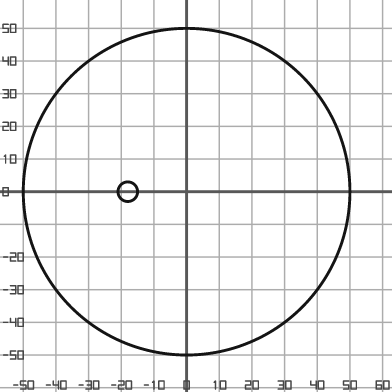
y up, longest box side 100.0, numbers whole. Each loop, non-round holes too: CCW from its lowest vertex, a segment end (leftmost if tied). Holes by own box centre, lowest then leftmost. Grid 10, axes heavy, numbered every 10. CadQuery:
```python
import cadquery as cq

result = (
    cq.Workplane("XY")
    .moveTo(0.0, 0.0)
    .circle(50.0)
    .moveTo(-18.0, 0.0)
    .circle(3.0)
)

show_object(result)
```